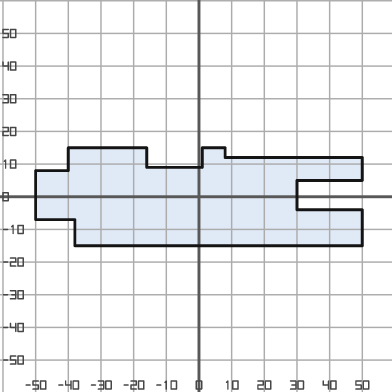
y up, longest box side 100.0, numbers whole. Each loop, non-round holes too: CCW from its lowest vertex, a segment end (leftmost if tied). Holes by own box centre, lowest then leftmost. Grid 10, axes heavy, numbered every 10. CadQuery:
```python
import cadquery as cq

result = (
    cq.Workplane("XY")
    .moveTo(-38.0, -15.0)
    .lineTo(50.0, -15.0)
    .lineTo(50.0, -4.0)
    .lineTo(30.0, -4.0)
    .lineTo(30.0, 5.0)
    .lineTo(50.0, 5.0)
    .lineTo(50.0, 12.0)
    .lineTo(8.0, 12.0)
    .lineTo(8.0, 15.0)
    .lineTo(1.0, 15.0)
    .lineTo(1.0, 9.0)
    .lineTo(-16.0, 9.0)
    .lineTo(-16.0, 15.0)
    .lineTo(-40.0, 15.0)
    .lineTo(-40.0, 8.0)
    .lineTo(-50.0, 8.0)
    .lineTo(-50.0, -7.0)
    .lineTo(-38.0, -7.0)
    .close()
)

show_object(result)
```